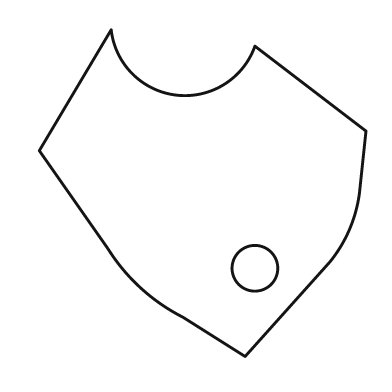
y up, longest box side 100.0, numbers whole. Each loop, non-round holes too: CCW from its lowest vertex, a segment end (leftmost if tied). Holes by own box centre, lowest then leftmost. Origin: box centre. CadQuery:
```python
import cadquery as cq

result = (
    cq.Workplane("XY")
    .moveTo(13.0, -50.0)
    .lineTo(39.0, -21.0)
    .threePointArc((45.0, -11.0), (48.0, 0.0))
    .lineTo(50.0, 19.0)
    .lineTo(16.0, 45.0)
    .threePointArc((-8.0, 30.0), (-28.0, 50.0))
    .lineTo(-50.0, 13.0)
    .lineTo(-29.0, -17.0)
    .threePointArc((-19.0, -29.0), (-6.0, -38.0))
    .close()
    .moveTo(16.0, -23.0)
    .circle(7.0)
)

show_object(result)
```